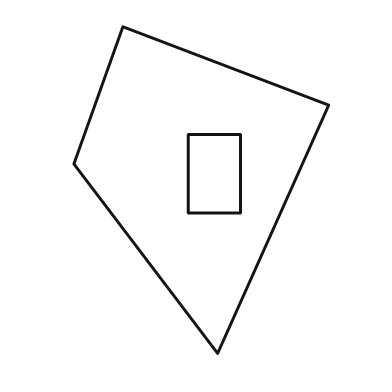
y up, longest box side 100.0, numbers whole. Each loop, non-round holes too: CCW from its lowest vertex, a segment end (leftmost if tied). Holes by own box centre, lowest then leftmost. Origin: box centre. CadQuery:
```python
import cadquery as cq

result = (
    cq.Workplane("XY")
    .moveTo(5.0, -50.0)
    .lineTo(39.0, 26.0)
    .lineTo(-24.0, 50.0)
    .lineTo(-39.0, 8.0)
    .close()
    .moveTo(-4.0, -7.0)
    .lineTo(12.0, -7.0)
    .lineTo(12.0, 17.0)
    .lineTo(-4.0, 17.0)
    .close()
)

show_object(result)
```